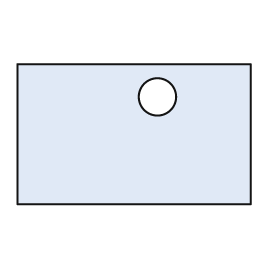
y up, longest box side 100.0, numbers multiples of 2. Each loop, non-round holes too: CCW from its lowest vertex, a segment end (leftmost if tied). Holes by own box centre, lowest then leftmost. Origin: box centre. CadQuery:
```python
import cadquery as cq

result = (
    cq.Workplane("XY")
    .moveTo(-50.0, -30.0)
    .lineTo(50.0, -30.0)
    .lineTo(50.0, 30.0)
    .lineTo(-50.0, 30.0)
    .close()
    .moveTo(10.0, 16.0)
    .circle(8.0)
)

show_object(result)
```